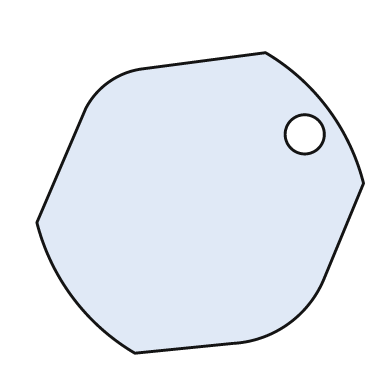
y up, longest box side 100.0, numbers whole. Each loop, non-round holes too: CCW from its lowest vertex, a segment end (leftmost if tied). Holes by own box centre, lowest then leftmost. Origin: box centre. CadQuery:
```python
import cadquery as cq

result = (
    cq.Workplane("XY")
    .moveTo(-20.0, -46.0)
    .lineTo(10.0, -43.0)
    .threePointArc((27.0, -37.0), (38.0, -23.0))
    .lineTo(50.0, 6.0)
    .threePointArc((39.0, 29.0), (20.0, 46.0))
    .lineTo(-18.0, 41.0)
    .threePointArc((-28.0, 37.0), (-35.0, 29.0))
    .lineTo(-50.0, -6.0)
    .threePointArc((-39.0, -29.0), (-20.0, -46.0))
    .close()
    .moveTo(32.0, 21.0)
    .circle(6.0)
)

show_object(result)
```